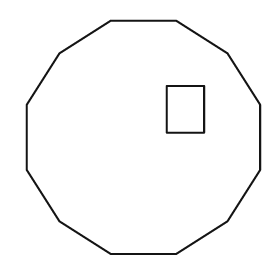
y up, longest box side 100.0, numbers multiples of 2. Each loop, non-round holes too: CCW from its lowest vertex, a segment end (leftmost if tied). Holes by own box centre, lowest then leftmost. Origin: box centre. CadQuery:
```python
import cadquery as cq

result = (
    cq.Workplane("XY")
    .moveTo(-14.0, -50.0)
    .lineTo(14.0, -50.0)
    .lineTo(36.0, -36.0)
    .lineTo(50.0, -14.0)
    .lineTo(50.0, 14.0)
    .lineTo(36.0, 36.0)
    .lineTo(14.0, 50.0)
    .lineTo(-14.0, 50.0)
    .lineTo(-36.0, 36.0)
    .lineTo(-50.0, 14.0)
    .lineTo(-50.0, -14.0)
    .lineTo(-36.0, -36.0)
    .close()
    .moveTo(10.0, 2.0)
    .lineTo(26.0, 2.0)
    .lineTo(26.0, 22.0)
    .lineTo(10.0, 22.0)
    .close()
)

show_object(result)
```